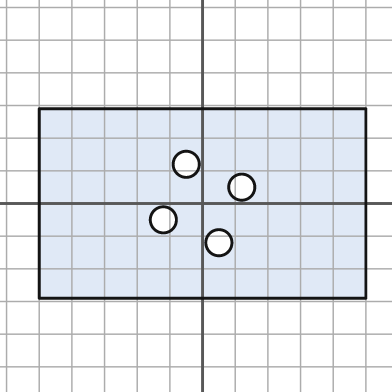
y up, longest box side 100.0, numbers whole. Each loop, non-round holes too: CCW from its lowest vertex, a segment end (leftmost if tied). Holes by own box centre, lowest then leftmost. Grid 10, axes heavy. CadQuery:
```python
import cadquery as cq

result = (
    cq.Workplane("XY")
    .moveTo(-50.0, -29.0)
    .lineTo(50.0, -29.0)
    .lineTo(50.0, 29.0)
    .lineTo(-50.0, 29.0)
    .close()
    .moveTo(5.0, -12.0)
    .circle(4.0)
    .moveTo(-12.0, -5.0)
    .circle(4.0)
    .moveTo(12.0, 5.0)
    .circle(4.0)
    .moveTo(-5.0, 12.0)
    .circle(4.0)
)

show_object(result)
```